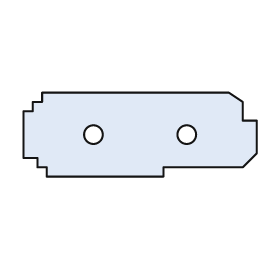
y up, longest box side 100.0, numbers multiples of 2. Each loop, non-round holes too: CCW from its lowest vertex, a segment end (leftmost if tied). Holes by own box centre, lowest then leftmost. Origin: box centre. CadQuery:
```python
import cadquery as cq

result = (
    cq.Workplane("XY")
    .moveTo(-40.0, -18.0)
    .lineTo(10.0, -18.0)
    .lineTo(10.0, -14.0)
    .lineTo(44.0, -14.0)
    .lineTo(50.0, -8.0)
    .lineTo(50.0, 6.0)
    .lineTo(44.0, 6.0)
    .lineTo(44.0, 14.0)
    .lineTo(38.0, 18.0)
    .lineTo(-42.0, 18.0)
    .lineTo(-42.0, 14.0)
    .lineTo(-46.0, 14.0)
    .lineTo(-46.0, 10.0)
    .lineTo(-50.0, 10.0)
    .lineTo(-50.0, -10.0)
    .lineTo(-44.0, -10.0)
    .lineTo(-44.0, -14.0)
    .lineTo(-40.0, -14.0)
    .close()
    .moveTo(-20.0, 0.0)
    .circle(4.0)
    .moveTo(20.0, 0.0)
    .circle(4.0)
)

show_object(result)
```